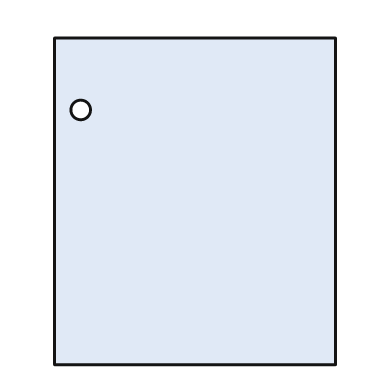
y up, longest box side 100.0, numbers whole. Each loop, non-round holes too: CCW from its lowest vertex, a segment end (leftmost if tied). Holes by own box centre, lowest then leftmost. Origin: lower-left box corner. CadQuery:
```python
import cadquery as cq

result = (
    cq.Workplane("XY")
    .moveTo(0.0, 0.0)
    .lineTo(86.0, 0.0)
    .lineTo(86.0, 100.0)
    .lineTo(0.0, 100.0)
    .close()
    .moveTo(8.0, 78.0)
    .circle(3.0)
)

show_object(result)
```